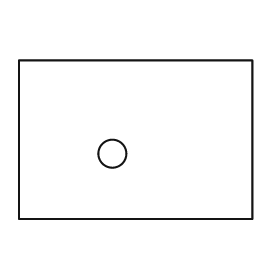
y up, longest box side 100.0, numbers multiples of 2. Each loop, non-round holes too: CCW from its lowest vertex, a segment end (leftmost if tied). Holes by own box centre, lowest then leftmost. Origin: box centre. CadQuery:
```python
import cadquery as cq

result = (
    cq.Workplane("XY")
    .moveTo(-50.0, -34.0)
    .lineTo(50.0, -34.0)
    .lineTo(50.0, 34.0)
    .lineTo(-50.0, 34.0)
    .close()
    .moveTo(-10.0, -6.0)
    .circle(6.0)
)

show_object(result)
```